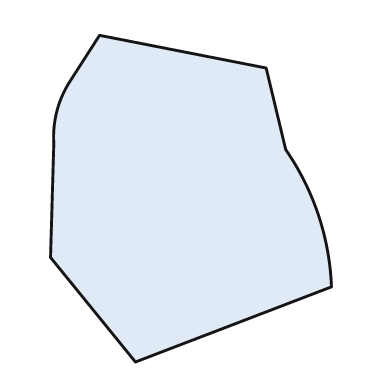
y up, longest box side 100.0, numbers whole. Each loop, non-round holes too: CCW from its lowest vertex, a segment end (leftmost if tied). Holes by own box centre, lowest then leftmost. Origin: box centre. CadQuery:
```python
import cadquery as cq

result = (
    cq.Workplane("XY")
    .moveTo(-17.0, -50.0)
    .lineTo(43.0, -27.0)
    .threePointArc((39.0, -5.0), (29.0, 15.0))
    .lineTo(23.0, 40.0)
    .lineTo(-28.0, 50.0)
    .lineTo(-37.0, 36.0)
    .threePointArc((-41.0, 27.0), (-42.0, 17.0))
    .lineTo(-43.0, -18.0)
    .close()
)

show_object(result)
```